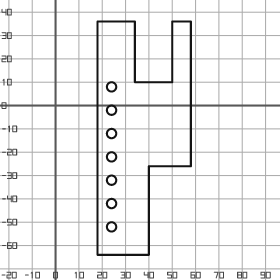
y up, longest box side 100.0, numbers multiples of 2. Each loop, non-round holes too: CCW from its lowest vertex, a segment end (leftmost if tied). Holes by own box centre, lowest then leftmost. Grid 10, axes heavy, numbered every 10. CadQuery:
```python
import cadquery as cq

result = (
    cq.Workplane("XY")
    .moveTo(18.0, -64.0)
    .lineTo(40.0, -64.0)
    .lineTo(40.0, -26.0)
    .lineTo(58.0, -26.0)
    .lineTo(58.0, 36.0)
    .lineTo(50.0, 36.0)
    .lineTo(50.0, 10.0)
    .lineTo(34.0, 10.0)
    .lineTo(34.0, 36.0)
    .lineTo(18.0, 36.0)
    .close()
    .moveTo(24.0, -52.0)
    .circle(2.0)
    .moveTo(24.0, -42.0)
    .circle(2.0)
    .moveTo(24.0, -32.0)
    .circle(2.0)
    .moveTo(24.0, -22.0)
    .circle(2.0)
    .moveTo(24.0, -12.0)
    .circle(2.0)
    .moveTo(24.0, -2.0)
    .circle(2.0)
    .moveTo(24.0, 8.0)
    .circle(2.0)
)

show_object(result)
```